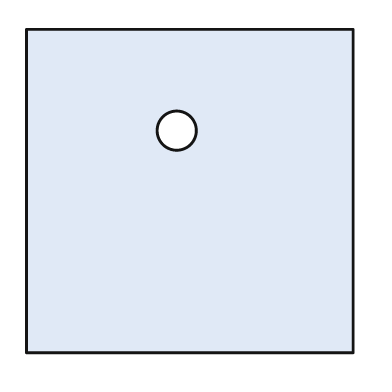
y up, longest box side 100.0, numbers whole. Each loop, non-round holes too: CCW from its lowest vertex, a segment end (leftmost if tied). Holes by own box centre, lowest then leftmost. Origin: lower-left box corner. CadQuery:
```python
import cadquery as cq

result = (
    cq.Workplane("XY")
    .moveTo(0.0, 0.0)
    .lineTo(100.0, 0.0)
    .lineTo(100.0, 99.0)
    .lineTo(0.0, 99.0)
    .close()
    .moveTo(46.0, 68.0)
    .circle(6.0)
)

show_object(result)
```